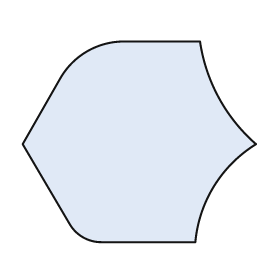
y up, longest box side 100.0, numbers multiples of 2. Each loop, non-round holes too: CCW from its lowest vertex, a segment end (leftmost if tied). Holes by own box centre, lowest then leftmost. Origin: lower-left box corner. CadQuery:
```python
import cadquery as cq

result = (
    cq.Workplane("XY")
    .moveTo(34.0, 0.0)
    .lineTo(74.0, 0.0)
    .threePointArc((82.0, 24.0), (100.0, 42.0))
    .threePointArc((84.0, 62.0), (76.0, 86.0))
    .lineTo(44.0, 86.0)
    .threePointArc((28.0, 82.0), (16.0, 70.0))
    .lineTo(0.0, 42.0)
    .lineTo(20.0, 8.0)
    .threePointArc((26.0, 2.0), (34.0, 0.0))
    .close()
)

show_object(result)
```